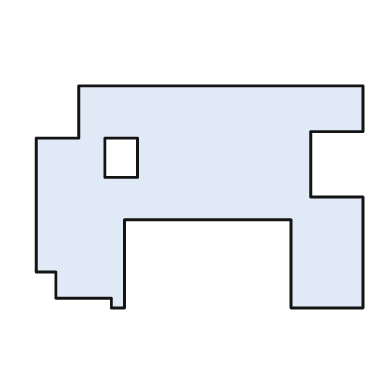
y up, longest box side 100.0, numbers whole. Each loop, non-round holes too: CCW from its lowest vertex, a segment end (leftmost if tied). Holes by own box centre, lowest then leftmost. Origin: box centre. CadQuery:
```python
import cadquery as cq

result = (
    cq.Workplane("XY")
    .moveTo(-27.0, -34.0)
    .lineTo(-23.0, -34.0)
    .lineTo(-23.0, -7.0)
    .lineTo(28.0, -7.0)
    .lineTo(28.0, -34.0)
    .lineTo(50.0, -34.0)
    .lineTo(50.0, 0.0)
    .lineTo(34.0, 0.0)
    .lineTo(34.0, 20.0)
    .lineTo(50.0, 20.0)
    .lineTo(50.0, 34.0)
    .lineTo(-37.0, 34.0)
    .lineTo(-37.0, 18.0)
    .lineTo(-50.0, 18.0)
    .lineTo(-50.0, -23.0)
    .lineTo(-44.0, -23.0)
    .lineTo(-44.0, -31.0)
    .lineTo(-27.0, -31.0)
    .close()
    .moveTo(-29.0, 6.0)
    .lineTo(-19.0, 6.0)
    .lineTo(-19.0, 18.0)
    .lineTo(-29.0, 18.0)
    .close()
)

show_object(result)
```